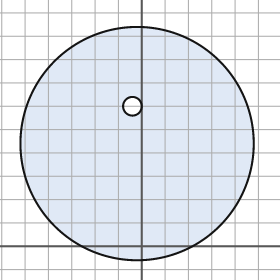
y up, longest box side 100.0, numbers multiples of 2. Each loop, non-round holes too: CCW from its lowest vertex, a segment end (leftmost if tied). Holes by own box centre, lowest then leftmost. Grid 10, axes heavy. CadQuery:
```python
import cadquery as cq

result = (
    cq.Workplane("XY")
    .moveTo(-2.0, 44.0)
    .circle(50.0)
    .moveTo(-4.0, 60.0)
    .circle(4.0)
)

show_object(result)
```